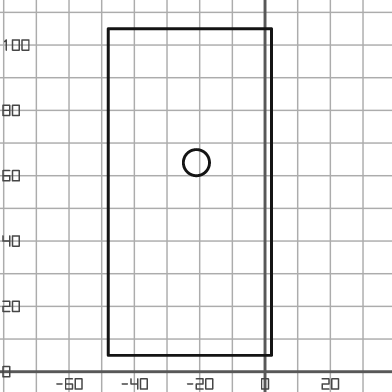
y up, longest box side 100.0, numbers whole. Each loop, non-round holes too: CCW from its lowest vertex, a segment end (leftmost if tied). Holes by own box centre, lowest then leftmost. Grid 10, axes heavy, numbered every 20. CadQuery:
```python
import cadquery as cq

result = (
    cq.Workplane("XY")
    .moveTo(-48.0, 5.0)
    .lineTo(2.0, 5.0)
    .lineTo(2.0, 105.0)
    .lineTo(-48.0, 105.0)
    .close()
    .moveTo(-21.0, 64.0)
    .circle(4.0)
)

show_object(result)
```